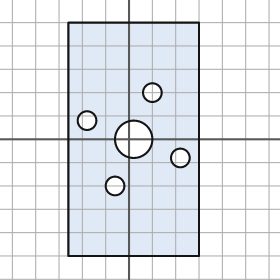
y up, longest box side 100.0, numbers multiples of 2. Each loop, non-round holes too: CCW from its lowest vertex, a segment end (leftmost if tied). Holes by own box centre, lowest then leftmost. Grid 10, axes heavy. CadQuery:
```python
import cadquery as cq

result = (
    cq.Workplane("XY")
    .moveTo(-26.0, -50.0)
    .lineTo(30.0, -50.0)
    .lineTo(30.0, 50.0)
    .lineTo(-26.0, 50.0)
    .close()
    .moveTo(-6.0, -20.0)
    .circle(4.0)
    .moveTo(22.0, -8.0)
    .circle(4.0)
    .moveTo(2.0, 0.0)
    .circle(8.0)
    .moveTo(-18.0, 8.0)
    .circle(4.0)
    .moveTo(10.0, 20.0)
    .circle(4.0)
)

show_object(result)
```